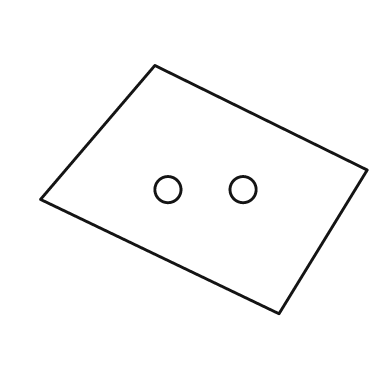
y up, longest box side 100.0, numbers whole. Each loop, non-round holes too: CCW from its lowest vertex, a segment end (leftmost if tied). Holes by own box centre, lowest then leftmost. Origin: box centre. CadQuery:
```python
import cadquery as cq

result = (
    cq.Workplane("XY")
    .moveTo(23.0, -38.0)
    .lineTo(50.0, 6.0)
    .lineTo(-15.0, 38.0)
    .lineTo(-50.0, -3.0)
    .close()
    .moveTo(-11.0, 0.0)
    .circle(4.0)
    .moveTo(12.0, 0.0)
    .circle(4.0)
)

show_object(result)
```